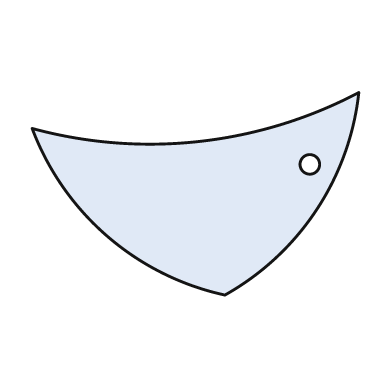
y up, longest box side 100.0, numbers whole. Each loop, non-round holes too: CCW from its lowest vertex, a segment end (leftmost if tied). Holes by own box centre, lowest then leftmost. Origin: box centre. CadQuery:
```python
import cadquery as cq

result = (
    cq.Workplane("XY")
    .moveTo(9.0, -31.0)
    .threePointArc((37.0, -5.0), (50.0, 31.0))
    .threePointArc((1.0, 16.0), (-50.0, 20.0))
    .threePointArc((-27.0, -13.0), (9.0, -31.0))
    .close()
    .moveTo(35.0, 9.0)
    .circle(3.0)
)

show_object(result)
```